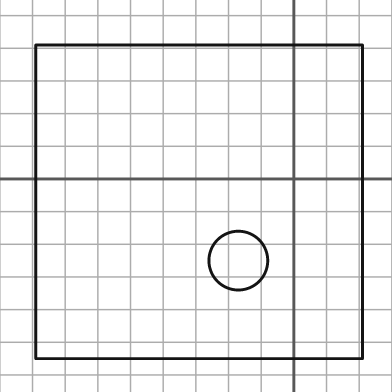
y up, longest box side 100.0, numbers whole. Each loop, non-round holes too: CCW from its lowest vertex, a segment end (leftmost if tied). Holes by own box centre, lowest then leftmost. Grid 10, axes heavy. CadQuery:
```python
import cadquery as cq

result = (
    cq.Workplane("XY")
    .moveTo(-79.0, -55.0)
    .lineTo(21.0, -55.0)
    .lineTo(21.0, 41.0)
    .lineTo(-79.0, 41.0)
    .close()
    .moveTo(-17.0, -25.0)
    .circle(9.0)
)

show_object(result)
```